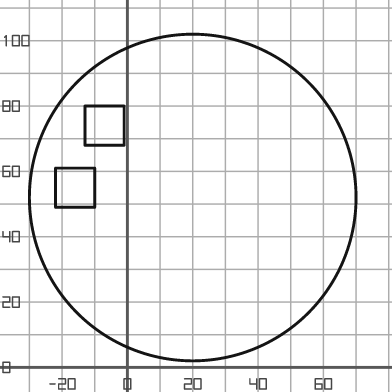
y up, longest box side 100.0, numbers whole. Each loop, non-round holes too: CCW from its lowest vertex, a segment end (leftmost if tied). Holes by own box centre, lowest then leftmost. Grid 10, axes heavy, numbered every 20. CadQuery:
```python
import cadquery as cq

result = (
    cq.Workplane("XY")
    .moveTo(20.0, 52.0)
    .circle(50.0)
    .moveTo(-22.0, 49.0)
    .lineTo(-10.0, 49.0)
    .lineTo(-10.0, 61.0)
    .lineTo(-22.0, 61.0)
    .close()
    .moveTo(-13.0, 68.0)
    .lineTo(-1.0, 68.0)
    .lineTo(-1.0, 80.0)
    .lineTo(-13.0, 80.0)
    .close()
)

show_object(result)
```